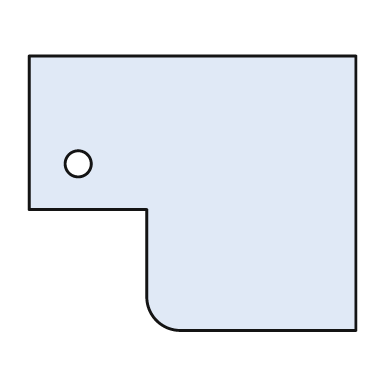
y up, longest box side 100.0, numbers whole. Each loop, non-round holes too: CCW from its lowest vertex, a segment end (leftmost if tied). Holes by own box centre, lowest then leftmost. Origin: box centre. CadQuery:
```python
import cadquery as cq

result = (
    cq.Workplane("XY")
    .moveTo(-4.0, -42.0)
    .lineTo(50.0, -42.0)
    .lineTo(50.0, 42.0)
    .lineTo(-50.0, 42.0)
    .lineTo(-50.0, -5.0)
    .lineTo(-14.0, -5.0)
    .lineTo(-14.0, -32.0)
    .threePointArc((-11.0, -39.0), (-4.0, -42.0))
    .close()
    .moveTo(-35.0, 9.0)
    .circle(4.0)
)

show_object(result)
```